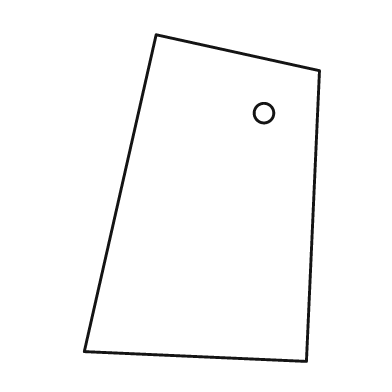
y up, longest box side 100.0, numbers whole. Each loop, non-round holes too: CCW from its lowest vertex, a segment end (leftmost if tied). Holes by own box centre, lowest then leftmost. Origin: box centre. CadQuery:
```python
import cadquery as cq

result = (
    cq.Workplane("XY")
    .moveTo(32.0, -50.0)
    .lineTo(36.0, 39.0)
    .lineTo(-14.0, 50.0)
    .lineTo(-36.0, -47.0)
    .close()
    .moveTo(19.0, 26.0)
    .circle(3.0)
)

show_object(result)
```